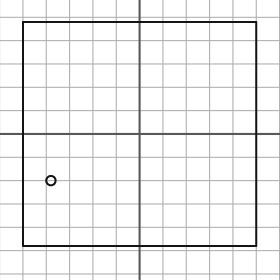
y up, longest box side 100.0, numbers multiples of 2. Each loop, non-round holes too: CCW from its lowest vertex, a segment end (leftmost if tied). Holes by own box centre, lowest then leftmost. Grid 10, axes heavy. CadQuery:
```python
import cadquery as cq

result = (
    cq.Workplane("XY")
    .moveTo(-50.0, -48.0)
    .lineTo(50.0, -48.0)
    .lineTo(50.0, 48.0)
    .lineTo(-50.0, 48.0)
    .close()
    .moveTo(-38.0, -20.0)
    .circle(2.0)
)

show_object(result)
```